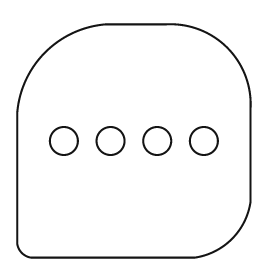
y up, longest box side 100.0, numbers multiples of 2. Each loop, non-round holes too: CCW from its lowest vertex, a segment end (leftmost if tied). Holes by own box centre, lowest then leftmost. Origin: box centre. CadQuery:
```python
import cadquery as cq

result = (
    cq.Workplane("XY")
    .moveTo(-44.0, -50.0)
    .lineTo(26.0, -50.0)
    .threePointArc((42.0, -42.0), (50.0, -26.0))
    .lineTo(50.0, 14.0)
    .threePointArc((40.0, 40.0), (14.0, 50.0))
    .lineTo(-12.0, 50.0)
    .threePointArc((-38.0, 38.0), (-50.0, 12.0))
    .lineTo(-50.0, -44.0)
    .threePointArc((-48.0, -48.0), (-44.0, -50.0))
    .close()
    .moveTo(-30.0, 0.0)
    .circle(6.0)
    .moveTo(-10.0, 0.0)
    .circle(6.0)
    .moveTo(10.0, 0.0)
    .circle(6.0)
    .moveTo(30.0, 0.0)
    .circle(6.0)
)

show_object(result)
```